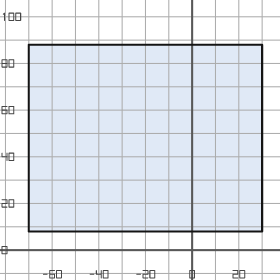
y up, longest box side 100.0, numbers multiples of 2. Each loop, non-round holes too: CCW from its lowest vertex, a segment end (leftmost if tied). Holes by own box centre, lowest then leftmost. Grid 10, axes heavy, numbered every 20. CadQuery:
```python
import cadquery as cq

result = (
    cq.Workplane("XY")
    .moveTo(-70.0, 8.0)
    .lineTo(30.0, 8.0)
    .lineTo(30.0, 88.0)
    .lineTo(-70.0, 88.0)
    .close()
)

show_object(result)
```